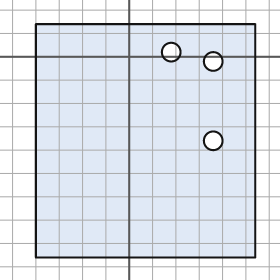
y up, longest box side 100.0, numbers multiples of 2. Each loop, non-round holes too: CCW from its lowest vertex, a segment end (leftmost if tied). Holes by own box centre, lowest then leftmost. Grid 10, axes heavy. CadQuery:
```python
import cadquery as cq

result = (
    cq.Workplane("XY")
    .moveTo(-40.0, -86.0)
    .lineTo(54.0, -86.0)
    .lineTo(54.0, 14.0)
    .lineTo(-40.0, 14.0)
    .close()
    .moveTo(36.0, -36.0)
    .circle(4.0)
    .moveTo(36.0, -2.0)
    .circle(4.0)
    .moveTo(18.0, 2.0)
    .circle(4.0)
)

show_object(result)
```